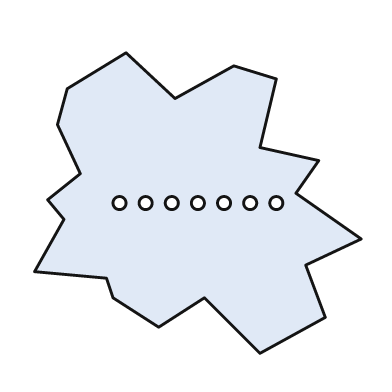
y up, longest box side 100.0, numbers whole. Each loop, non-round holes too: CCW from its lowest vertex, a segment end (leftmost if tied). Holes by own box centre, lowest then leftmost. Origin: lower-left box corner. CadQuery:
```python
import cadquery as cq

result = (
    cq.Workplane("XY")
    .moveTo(69.0, 0.0)
    .lineTo(89.0, 11.0)
    .lineTo(83.0, 27.0)
    .lineTo(100.0, 35.0)
    .lineTo(80.0, 49.0)
    .lineTo(87.0, 59.0)
    .lineTo(69.0, 63.0)
    .lineTo(74.0, 84.0)
    .lineTo(61.0, 88.0)
    .lineTo(43.0, 78.0)
    .lineTo(28.0, 92.0)
    .lineTo(10.0, 81.0)
    .lineTo(7.0, 70.0)
    .lineTo(14.0, 55.0)
    .lineTo(4.0, 47.0)
    .lineTo(9.0, 41.0)
    .lineTo(0.0, 25.0)
    .lineTo(22.0, 23.0)
    .lineTo(24.0, 17.0)
    .lineTo(38.0, 8.0)
    .lineTo(52.0, 17.0)
    .close()
    .moveTo(26.0, 46.0)
    .circle(2.0)
    .moveTo(34.0, 46.0)
    .circle(2.0)
    .moveTo(42.0, 46.0)
    .circle(2.0)
    .moveTo(50.0, 46.0)
    .circle(2.0)
    .moveTo(58.0, 46.0)
    .circle(2.0)
    .moveTo(66.0, 46.0)
    .circle(2.0)
    .moveTo(74.0, 46.0)
    .circle(2.0)
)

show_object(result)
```